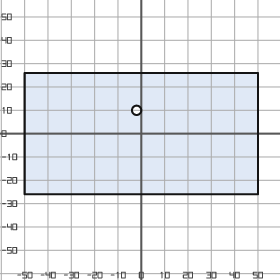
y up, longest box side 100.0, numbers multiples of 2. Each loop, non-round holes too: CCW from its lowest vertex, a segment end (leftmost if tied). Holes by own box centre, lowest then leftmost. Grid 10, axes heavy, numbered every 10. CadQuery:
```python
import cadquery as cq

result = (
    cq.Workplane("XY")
    .moveTo(-50.0, -26.0)
    .lineTo(50.0, -26.0)
    .lineTo(50.0, 26.0)
    .lineTo(-50.0, 26.0)
    .close()
    .moveTo(-2.0, 10.0)
    .circle(2.0)
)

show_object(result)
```